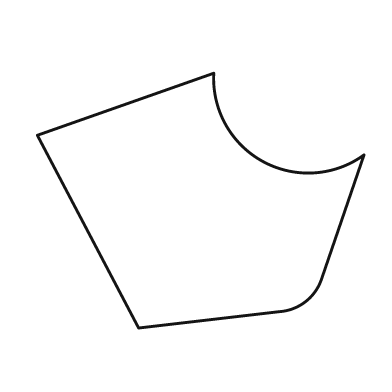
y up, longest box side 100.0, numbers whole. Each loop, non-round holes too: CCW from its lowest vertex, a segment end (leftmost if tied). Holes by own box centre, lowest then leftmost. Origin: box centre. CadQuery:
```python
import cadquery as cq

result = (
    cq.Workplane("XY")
    .moveTo(-19.0, -39.0)
    .lineTo(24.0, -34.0)
    .threePointArc((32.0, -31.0), (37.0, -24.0))
    .lineTo(50.0, 14.0)
    .threePointArc((19.0, 12.0), (4.0, 39.0))
    .lineTo(-50.0, 20.0)
    .close()
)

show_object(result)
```